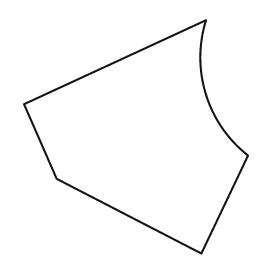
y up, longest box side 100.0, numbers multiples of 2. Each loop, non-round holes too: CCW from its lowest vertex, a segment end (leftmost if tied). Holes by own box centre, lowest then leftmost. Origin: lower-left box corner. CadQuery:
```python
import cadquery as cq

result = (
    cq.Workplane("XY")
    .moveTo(76.0, 0.0)
    .lineTo(96.0, 42.0)
    .threePointArc((78.0, 68.0), (78.0, 100.0))
    .lineTo(0.0, 64.0)
    .lineTo(14.0, 32.0)
    .close()
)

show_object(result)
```